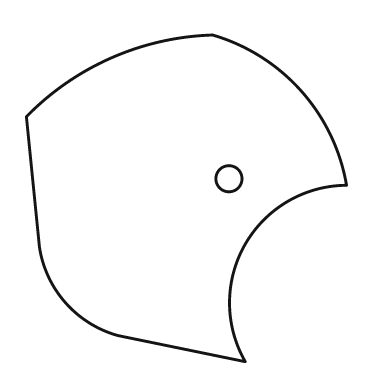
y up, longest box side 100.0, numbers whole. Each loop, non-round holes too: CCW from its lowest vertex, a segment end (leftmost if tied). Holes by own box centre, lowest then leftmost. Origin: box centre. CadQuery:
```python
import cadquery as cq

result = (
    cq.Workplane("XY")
    .moveTo(18.0, -50.0)
    .threePointArc((18.0, -14.0), (49.0, 4.0))
    .threePointArc((35.0, 33.0), (8.0, 50.0))
    .threePointArc((-23.0, 43.0), (-49.0, 25.0))
    .lineTo(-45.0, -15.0)
    .threePointArc((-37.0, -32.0), (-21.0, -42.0))
    .close()
    .moveTo(13.0, 6.0)
    .circle(4.0)
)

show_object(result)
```